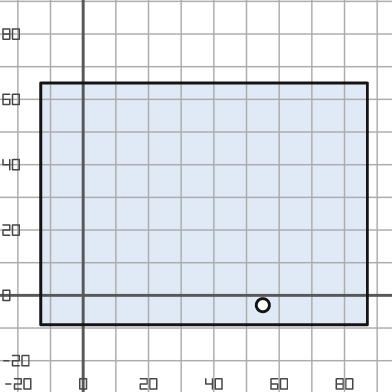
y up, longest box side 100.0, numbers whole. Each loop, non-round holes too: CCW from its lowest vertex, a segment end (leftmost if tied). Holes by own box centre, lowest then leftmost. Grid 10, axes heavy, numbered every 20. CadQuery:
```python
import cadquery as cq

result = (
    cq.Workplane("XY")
    .moveTo(-13.0, -9.0)
    .lineTo(87.0, -9.0)
    .lineTo(87.0, 65.0)
    .lineTo(-13.0, 65.0)
    .close()
    .moveTo(55.0, -3.0)
    .circle(2.0)
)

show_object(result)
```